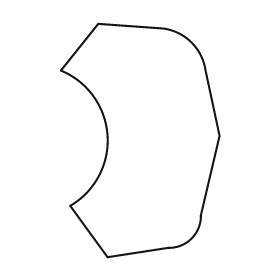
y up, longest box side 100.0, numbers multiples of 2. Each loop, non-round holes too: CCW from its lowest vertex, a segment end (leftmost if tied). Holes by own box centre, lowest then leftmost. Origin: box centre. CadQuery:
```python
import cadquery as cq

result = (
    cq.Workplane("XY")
    .moveTo(-14.0, -50.0)
    .lineTo(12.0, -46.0)
    .threePointArc((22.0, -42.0), (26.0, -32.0))
    .lineTo(34.0, 2.0)
    .lineTo(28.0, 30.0)
    .threePointArc((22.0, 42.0), (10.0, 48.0))
    .lineTo(-18.0, 50.0)
    .lineTo(-34.0, 30.0)
    .threePointArc((-14.0, 2.0), (-30.0, -28.0))
    .close()
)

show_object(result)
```